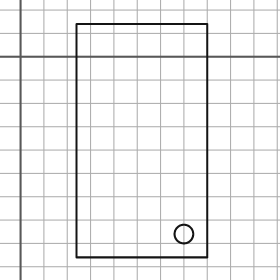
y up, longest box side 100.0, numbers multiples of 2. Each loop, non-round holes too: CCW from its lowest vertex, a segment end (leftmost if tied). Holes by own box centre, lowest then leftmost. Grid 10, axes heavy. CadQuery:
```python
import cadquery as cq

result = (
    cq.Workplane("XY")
    .moveTo(24.0, -86.0)
    .lineTo(80.0, -86.0)
    .lineTo(80.0, 14.0)
    .lineTo(24.0, 14.0)
    .close()
    .moveTo(70.0, -76.0)
    .circle(4.0)
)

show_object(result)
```